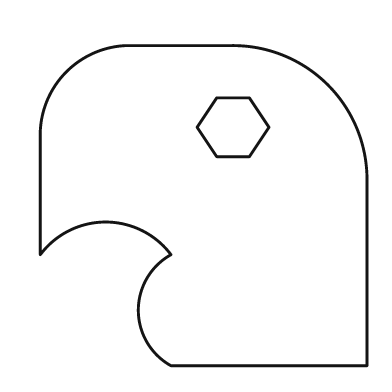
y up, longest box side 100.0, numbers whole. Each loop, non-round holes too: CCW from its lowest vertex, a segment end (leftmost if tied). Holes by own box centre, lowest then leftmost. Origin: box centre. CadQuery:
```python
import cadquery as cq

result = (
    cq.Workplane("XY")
    .moveTo(-10.0, -49.0)
    .lineTo(50.0, -49.0)
    .lineTo(50.0, 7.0)
    .threePointArc((38.0, 37.0), (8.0, 49.0))
    .lineTo(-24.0, 49.0)
    .threePointArc((-42.0, 41.0), (-50.0, 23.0))
    .lineTo(-50.0, -15.0)
    .threePointArc((-30.0, -5.0), (-10.0, -15.0))
    .threePointArc((-20.0, -32.0), (-10.0, -49.0))
    .close()
    .moveTo(4.0, 15.0)
    .lineTo(14.0, 15.0)
    .lineTo(20.0, 24.0)
    .lineTo(14.0, 33.0)
    .lineTo(4.0, 33.0)
    .lineTo(-2.0, 24.0)
    .close()
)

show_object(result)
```